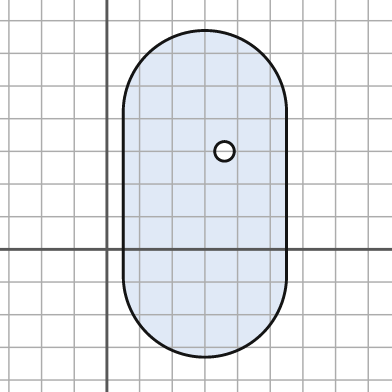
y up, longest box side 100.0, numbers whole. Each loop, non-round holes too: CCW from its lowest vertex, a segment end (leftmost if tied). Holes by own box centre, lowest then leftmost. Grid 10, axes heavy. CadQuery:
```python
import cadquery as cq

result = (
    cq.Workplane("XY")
    .moveTo(5.0, -8.0)
    .threePointArc((30.0, -33.0), (55.0, -8.0))
    .lineTo(55.0, 42.0)
    .threePointArc((30.0, 67.0), (5.0, 42.0))
    .close()
    .moveTo(36.0, 30.0)
    .circle(3.0)
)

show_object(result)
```